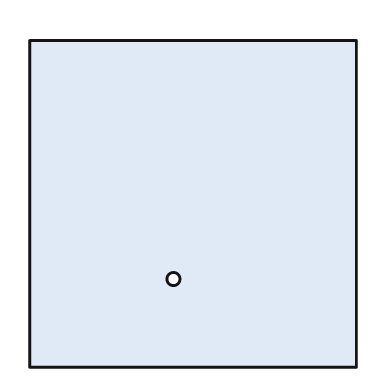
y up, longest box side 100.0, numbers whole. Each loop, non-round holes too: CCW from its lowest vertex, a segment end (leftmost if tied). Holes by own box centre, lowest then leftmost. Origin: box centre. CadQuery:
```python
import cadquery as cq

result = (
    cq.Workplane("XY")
    .moveTo(-50.0, -50.0)
    .lineTo(50.0, -50.0)
    .lineTo(50.0, 50.0)
    .lineTo(-50.0, 50.0)
    .close()
    .moveTo(-6.0, -23.0)
    .circle(2.0)
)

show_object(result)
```